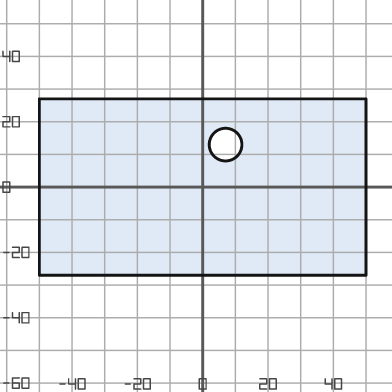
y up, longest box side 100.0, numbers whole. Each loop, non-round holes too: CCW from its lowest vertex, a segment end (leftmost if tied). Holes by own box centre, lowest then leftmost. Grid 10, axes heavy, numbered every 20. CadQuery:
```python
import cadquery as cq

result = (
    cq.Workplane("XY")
    .moveTo(-50.0, -27.0)
    .lineTo(50.0, -27.0)
    .lineTo(50.0, 27.0)
    .lineTo(-50.0, 27.0)
    .close()
    .moveTo(7.0, 13.0)
    .circle(5.0)
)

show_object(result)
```